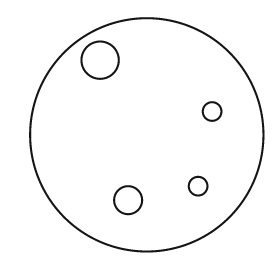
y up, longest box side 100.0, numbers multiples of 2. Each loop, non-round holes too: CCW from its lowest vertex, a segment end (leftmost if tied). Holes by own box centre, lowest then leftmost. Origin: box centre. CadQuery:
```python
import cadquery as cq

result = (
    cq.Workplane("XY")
    .moveTo(0.0, 0.0)
    .circle(50.0)
    .moveTo(-8.0, -28.0)
    .circle(6.0)
    .moveTo(22.0, -22.0)
    .circle(4.0)
    .moveTo(28.0, 10.0)
    .circle(4.0)
    .moveTo(-20.0, 32.0)
    .circle(8.0)
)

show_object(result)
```